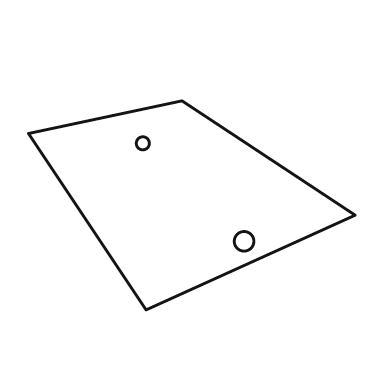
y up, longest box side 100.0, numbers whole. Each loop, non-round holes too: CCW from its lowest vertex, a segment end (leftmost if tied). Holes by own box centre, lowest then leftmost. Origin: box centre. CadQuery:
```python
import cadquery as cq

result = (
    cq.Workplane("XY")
    .moveTo(-14.0, -32.0)
    .lineTo(50.0, -3.0)
    .lineTo(-3.0, 32.0)
    .lineTo(-50.0, 22.0)
    .close()
    .moveTo(16.0, -11.0)
    .circle(3.0)
    .moveTo(-15.0, 19.0)
    .circle(2.0)
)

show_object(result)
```